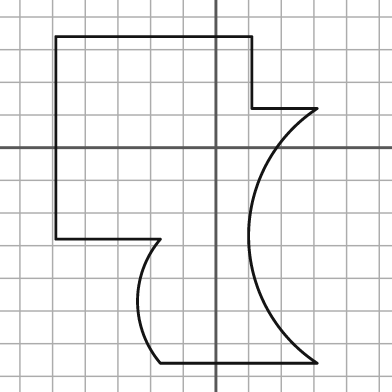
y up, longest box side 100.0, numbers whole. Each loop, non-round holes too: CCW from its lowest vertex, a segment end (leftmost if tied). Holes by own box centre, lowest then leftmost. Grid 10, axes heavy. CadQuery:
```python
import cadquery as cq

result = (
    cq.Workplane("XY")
    .moveTo(-17.0, -66.0)
    .lineTo(31.0, -66.0)
    .threePointArc((10.0, -27.0), (31.0, 12.0))
    .lineTo(11.0, 12.0)
    .lineTo(11.0, 34.0)
    .lineTo(-49.0, 34.0)
    .lineTo(-49.0, -28.0)
    .lineTo(-17.0, -28.0)
    .threePointArc((-24.0, -47.0), (-17.0, -66.0))
    .close()
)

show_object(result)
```